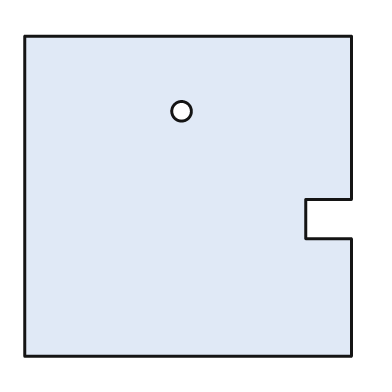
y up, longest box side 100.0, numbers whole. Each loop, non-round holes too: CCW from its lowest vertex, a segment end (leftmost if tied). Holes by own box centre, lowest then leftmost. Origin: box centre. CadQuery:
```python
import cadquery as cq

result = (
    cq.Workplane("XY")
    .moveTo(-50.0, -49.0)
    .lineTo(50.0, -49.0)
    .lineTo(50.0, -13.0)
    .lineTo(36.0, -13.0)
    .lineTo(36.0, -1.0)
    .lineTo(50.0, -1.0)
    .lineTo(50.0, 49.0)
    .lineTo(-50.0, 49.0)
    .close()
    .moveTo(-2.0, 26.0)
    .circle(3.0)
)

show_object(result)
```